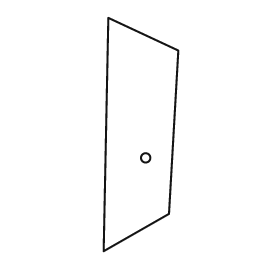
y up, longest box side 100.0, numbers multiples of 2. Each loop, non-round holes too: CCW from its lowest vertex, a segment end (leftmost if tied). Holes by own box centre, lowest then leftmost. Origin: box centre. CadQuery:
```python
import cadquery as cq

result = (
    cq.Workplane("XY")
    .moveTo(-16.0, -50.0)
    .lineTo(12.0, -34.0)
    .lineTo(16.0, 36.0)
    .lineTo(-14.0, 50.0)
    .close()
    .moveTo(2.0, -10.0)
    .circle(2.0)
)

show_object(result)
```